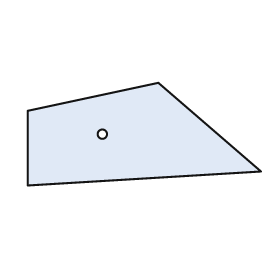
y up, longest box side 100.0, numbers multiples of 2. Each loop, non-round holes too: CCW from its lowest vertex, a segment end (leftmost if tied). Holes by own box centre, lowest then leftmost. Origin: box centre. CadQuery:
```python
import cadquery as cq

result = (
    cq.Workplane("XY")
    .moveTo(-50.0, -22.0)
    .lineTo(50.0, -16.0)
    .lineTo(6.0, 22.0)
    .lineTo(-50.0, 10.0)
    .close()
    .moveTo(-18.0, 0.0)
    .circle(2.0)
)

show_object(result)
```